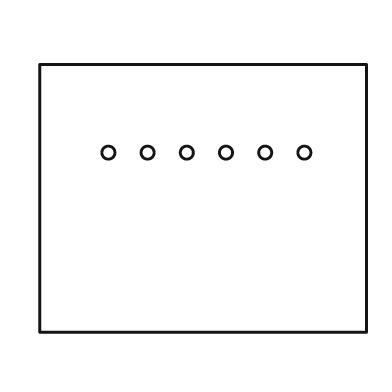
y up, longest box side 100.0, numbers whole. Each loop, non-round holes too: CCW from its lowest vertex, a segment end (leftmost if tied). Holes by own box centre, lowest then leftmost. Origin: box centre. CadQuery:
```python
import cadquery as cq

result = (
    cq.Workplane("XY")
    .moveTo(-50.0, -41.0)
    .lineTo(50.0, -41.0)
    .lineTo(50.0, 41.0)
    .lineTo(-50.0, 41.0)
    .close()
    .moveTo(-29.0, 14.0)
    .circle(2.0)
    .moveTo(-17.0, 14.0)
    .circle(2.0)
    .moveTo(-5.0, 14.0)
    .circle(2.0)
    .moveTo(7.0, 14.0)
    .circle(2.0)
    .moveTo(19.0, 14.0)
    .circle(2.0)
    .moveTo(31.0, 14.0)
    .circle(2.0)
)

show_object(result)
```